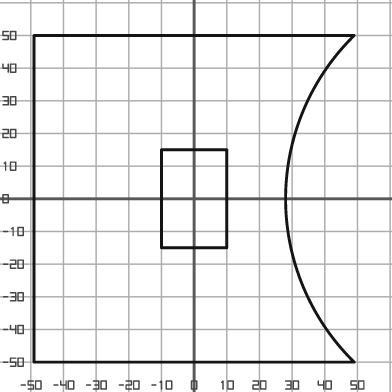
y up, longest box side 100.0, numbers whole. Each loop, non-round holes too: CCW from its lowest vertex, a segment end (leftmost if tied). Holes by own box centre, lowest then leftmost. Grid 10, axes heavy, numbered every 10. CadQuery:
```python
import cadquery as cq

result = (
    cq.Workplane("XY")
    .moveTo(-49.0, -50.0)
    .lineTo(49.0, -50.0)
    .threePointArc((28.0, 0.0), (49.0, 50.0))
    .lineTo(-49.0, 50.0)
    .close()
    .moveTo(-10.0, -15.0)
    .lineTo(10.0, -15.0)
    .lineTo(10.0, 15.0)
    .lineTo(-10.0, 15.0)
    .close()
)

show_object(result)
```